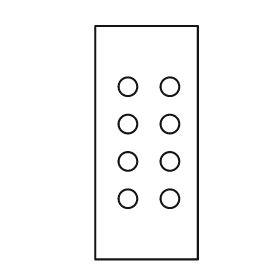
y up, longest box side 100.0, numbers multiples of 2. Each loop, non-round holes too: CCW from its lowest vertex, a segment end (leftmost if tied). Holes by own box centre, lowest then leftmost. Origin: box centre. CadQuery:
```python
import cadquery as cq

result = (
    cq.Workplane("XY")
    .moveTo(-22.0, -50.0)
    .lineTo(22.0, -50.0)
    .lineTo(22.0, 50.0)
    .lineTo(-22.0, 50.0)
    .close()
    .moveTo(-8.0, -24.0)
    .circle(4.0)
    .moveTo(10.0, -24.0)
    .circle(4.0)
    .moveTo(-8.0, -8.0)
    .circle(4.0)
    .moveTo(10.0, -8.0)
    .circle(4.0)
    .moveTo(-8.0, 8.0)
    .circle(4.0)
    .moveTo(10.0, 8.0)
    .circle(4.0)
    .moveTo(-8.0, 24.0)
    .circle(4.0)
    .moveTo(10.0, 24.0)
    .circle(4.0)
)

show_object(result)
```